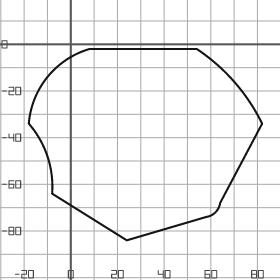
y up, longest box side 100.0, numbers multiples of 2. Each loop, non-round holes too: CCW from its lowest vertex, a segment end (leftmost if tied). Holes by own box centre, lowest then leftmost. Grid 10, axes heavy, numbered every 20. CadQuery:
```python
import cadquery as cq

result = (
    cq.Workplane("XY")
    .moveTo(24.0, -84.0)
    .lineTo(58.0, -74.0)
    .threePointArc((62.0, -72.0), (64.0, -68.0))
    .lineTo(82.0, -34.0)
    .threePointArc((70.0, -16.0), (54.0, -2.0))
    .lineTo(8.0, -2.0)
    .threePointArc((-10.0, -14.0), (-18.0, -34.0))
    .threePointArc((-10.0, -48.0), (-8.0, -64.0))
    .close()
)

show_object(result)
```